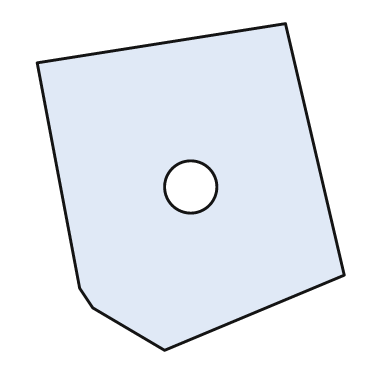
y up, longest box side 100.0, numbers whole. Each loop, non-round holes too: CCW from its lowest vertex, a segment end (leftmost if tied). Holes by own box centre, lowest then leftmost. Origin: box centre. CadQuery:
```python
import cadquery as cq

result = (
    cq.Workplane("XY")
    .moveTo(-8.0, -50.0)
    .lineTo(47.0, -27.0)
    .lineTo(29.0, 50.0)
    .lineTo(-47.0, 38.0)
    .lineTo(-34.0, -31.0)
    .lineTo(-30.0, -37.0)
    .close()
    .moveTo(0.0, 0.0)
    .circle(8.0)
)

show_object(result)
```